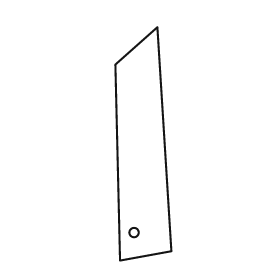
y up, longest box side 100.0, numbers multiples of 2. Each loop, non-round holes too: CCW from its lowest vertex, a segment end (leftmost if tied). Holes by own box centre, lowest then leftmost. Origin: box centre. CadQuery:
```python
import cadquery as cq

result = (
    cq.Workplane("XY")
    .moveTo(-10.0, -50.0)
    .lineTo(12.0, -46.0)
    .lineTo(6.0, 50.0)
    .lineTo(-12.0, 34.0)
    .close()
    .moveTo(-4.0, -38.0)
    .circle(2.0)
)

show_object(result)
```